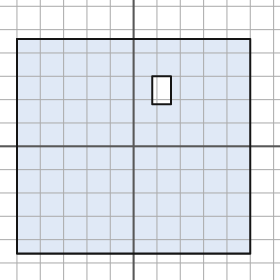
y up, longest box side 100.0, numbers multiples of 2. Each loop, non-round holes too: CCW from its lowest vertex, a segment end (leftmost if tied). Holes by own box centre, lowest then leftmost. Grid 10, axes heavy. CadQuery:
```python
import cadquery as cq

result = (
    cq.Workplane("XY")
    .moveTo(-50.0, -46.0)
    .lineTo(50.0, -46.0)
    .lineTo(50.0, 46.0)
    .lineTo(-50.0, 46.0)
    .close()
    .moveTo(8.0, 18.0)
    .lineTo(16.0, 18.0)
    .lineTo(16.0, 30.0)
    .lineTo(8.0, 30.0)
    .close()
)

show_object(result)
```